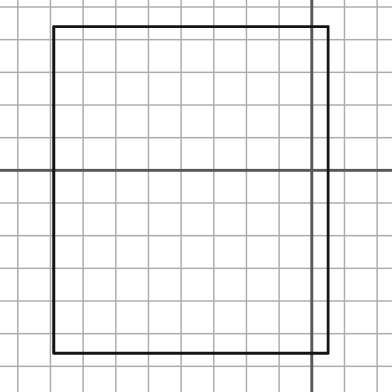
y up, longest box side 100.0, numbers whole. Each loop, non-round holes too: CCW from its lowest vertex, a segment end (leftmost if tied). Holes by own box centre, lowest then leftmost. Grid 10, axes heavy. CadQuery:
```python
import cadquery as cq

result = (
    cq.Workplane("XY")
    .moveTo(-79.0, -56.0)
    .lineTo(5.0, -56.0)
    .lineTo(5.0, 44.0)
    .lineTo(-79.0, 44.0)
    .close()
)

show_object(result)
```